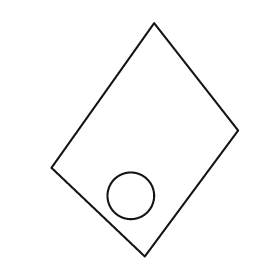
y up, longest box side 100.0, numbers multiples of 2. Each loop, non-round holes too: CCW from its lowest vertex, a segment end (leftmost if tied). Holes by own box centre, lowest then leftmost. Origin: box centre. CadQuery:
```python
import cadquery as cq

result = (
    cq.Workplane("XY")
    .moveTo(0.0, -50.0)
    .lineTo(40.0, 4.0)
    .lineTo(4.0, 50.0)
    .lineTo(-40.0, -12.0)
    .close()
    .moveTo(-6.0, -24.0)
    .circle(10.0)
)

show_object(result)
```